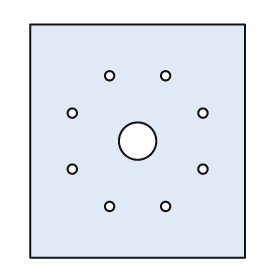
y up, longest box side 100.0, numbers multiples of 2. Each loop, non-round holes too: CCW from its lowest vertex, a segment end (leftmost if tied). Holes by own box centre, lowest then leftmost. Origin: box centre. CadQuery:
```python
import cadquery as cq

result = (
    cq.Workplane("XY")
    .moveTo(-46.0, -50.0)
    .lineTo(46.0, -50.0)
    .lineTo(46.0, 50.0)
    .lineTo(-46.0, 50.0)
    .close()
    .moveTo(-12.0, -28.0)
    .circle(2.0)
    .moveTo(12.0, -28.0)
    .circle(2.0)
    .moveTo(-28.0, -12.0)
    .circle(2.0)
    .moveTo(28.0, -12.0)
    .circle(2.0)
    .moveTo(0.0, 0.0)
    .circle(8.0)
    .moveTo(-28.0, 12.0)
    .circle(2.0)
    .moveTo(28.0, 12.0)
    .circle(2.0)
    .moveTo(-12.0, 28.0)
    .circle(2.0)
    .moveTo(12.0, 28.0)
    .circle(2.0)
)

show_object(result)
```